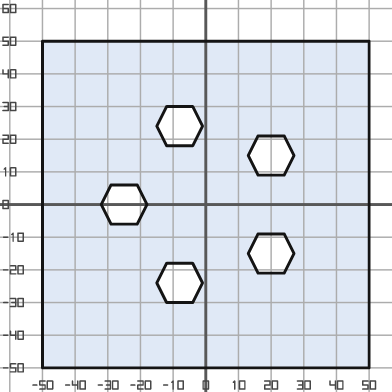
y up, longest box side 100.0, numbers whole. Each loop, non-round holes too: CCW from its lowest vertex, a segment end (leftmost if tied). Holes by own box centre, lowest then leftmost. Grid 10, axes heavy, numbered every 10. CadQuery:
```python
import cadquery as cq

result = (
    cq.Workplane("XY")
    .moveTo(-50.0, -50.0)
    .lineTo(50.0, -50.0)
    .lineTo(50.0, 50.0)
    .lineTo(-50.0, 50.0)
    .close()
    .moveTo(-12.0, -30.0)
    .lineTo(-4.0, -30.0)
    .lineTo(-1.0, -24.0)
    .lineTo(-4.0, -18.0)
    .lineTo(-12.0, -18.0)
    .lineTo(-15.0, -24.0)
    .close()
    .moveTo(16.0, -21.0)
    .lineTo(24.0, -21.0)
    .lineTo(27.0, -15.0)
    .lineTo(24.0, -9.0)
    .lineTo(16.0, -9.0)
    .lineTo(13.0, -15.0)
    .close()
    .moveTo(-29.0, -6.0)
    .lineTo(-21.0, -6.0)
    .lineTo(-18.0, 0.0)
    .lineTo(-21.0, 6.0)
    .lineTo(-29.0, 6.0)
    .lineTo(-32.0, 0.0)
    .close()
    .moveTo(16.0, 9.0)
    .lineTo(24.0, 9.0)
    .lineTo(27.0, 15.0)
    .lineTo(24.0, 21.0)
    .lineTo(16.0, 21.0)
    .lineTo(13.0, 15.0)
    .close()
    .moveTo(-12.0, 18.0)
    .lineTo(-4.0, 18.0)
    .lineTo(-1.0, 24.0)
    .lineTo(-4.0, 30.0)
    .lineTo(-12.0, 30.0)
    .lineTo(-15.0, 24.0)
    .close()
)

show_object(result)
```